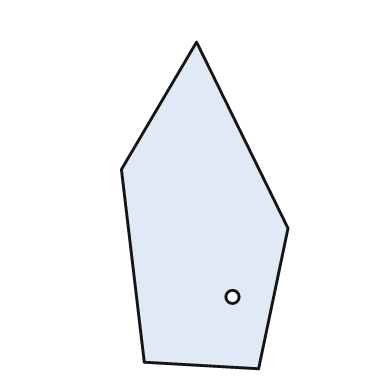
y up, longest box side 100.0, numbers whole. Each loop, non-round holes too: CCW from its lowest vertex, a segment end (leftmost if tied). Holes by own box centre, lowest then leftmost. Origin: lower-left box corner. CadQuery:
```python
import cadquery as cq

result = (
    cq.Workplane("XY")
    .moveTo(42.0, 0.0)
    .lineTo(51.0, 43.0)
    .lineTo(23.0, 100.0)
    .lineTo(0.0, 61.0)
    .lineTo(7.0, 2.0)
    .close()
    .moveTo(34.0, 22.0)
    .circle(2.0)
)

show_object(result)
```